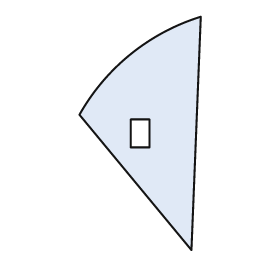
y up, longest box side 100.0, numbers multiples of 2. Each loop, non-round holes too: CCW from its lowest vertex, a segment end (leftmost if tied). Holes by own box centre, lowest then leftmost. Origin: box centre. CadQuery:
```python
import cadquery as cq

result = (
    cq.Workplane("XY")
    .moveTo(22.0, -50.0)
    .lineTo(26.0, 50.0)
    .threePointArc((-4.0, 34.0), (-26.0, 8.0))
    .close()
    .moveTo(-4.0, -6.0)
    .lineTo(4.0, -6.0)
    .lineTo(4.0, 6.0)
    .lineTo(-4.0, 6.0)
    .close()
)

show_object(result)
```